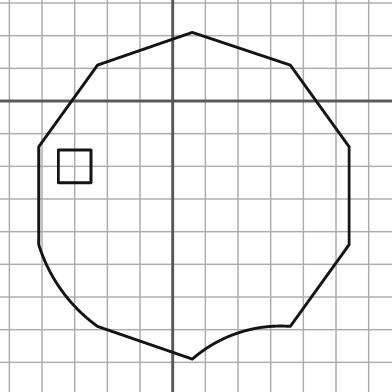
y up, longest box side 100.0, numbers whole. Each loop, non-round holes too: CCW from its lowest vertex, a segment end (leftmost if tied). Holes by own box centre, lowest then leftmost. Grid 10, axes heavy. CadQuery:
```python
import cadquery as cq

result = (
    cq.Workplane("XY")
    .moveTo(6.0, -79.0)
    .threePointArc((20.0, -71.0), (36.0, -69.0))
    .lineTo(54.0, -44.0)
    .lineTo(54.0, -14.0)
    .lineTo(36.0, 11.0)
    .lineTo(6.0, 21.0)
    .lineTo(-23.0, 11.0)
    .lineTo(-41.0, -14.0)
    .lineTo(-41.0, -44.0)
    .threePointArc((-34.0, -58.0), (-23.0, -69.0))
    .close()
    .moveTo(-35.0, -25.0)
    .lineTo(-25.0, -25.0)
    .lineTo(-25.0, -15.0)
    .lineTo(-35.0, -15.0)
    .close()
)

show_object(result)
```